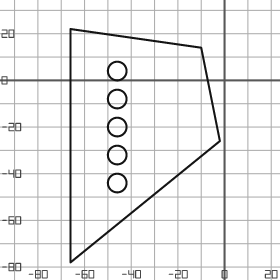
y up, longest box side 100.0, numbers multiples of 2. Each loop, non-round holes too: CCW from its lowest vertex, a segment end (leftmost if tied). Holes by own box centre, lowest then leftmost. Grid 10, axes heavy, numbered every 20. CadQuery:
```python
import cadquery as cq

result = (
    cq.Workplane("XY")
    .moveTo(-66.0, -78.0)
    .lineTo(-2.0, -26.0)
    .lineTo(-10.0, 14.0)
    .lineTo(-66.0, 22.0)
    .close()
    .moveTo(-46.0, -44.0)
    .circle(4.0)
    .moveTo(-46.0, -32.0)
    .circle(4.0)
    .moveTo(-46.0, -20.0)
    .circle(4.0)
    .moveTo(-46.0, -8.0)
    .circle(4.0)
    .moveTo(-46.0, 4.0)
    .circle(4.0)
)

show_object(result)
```